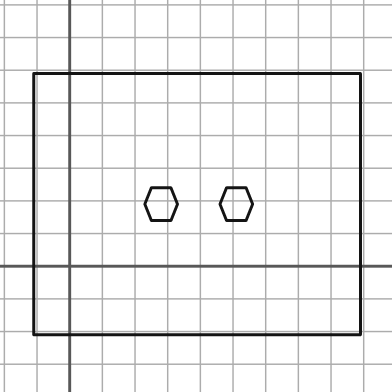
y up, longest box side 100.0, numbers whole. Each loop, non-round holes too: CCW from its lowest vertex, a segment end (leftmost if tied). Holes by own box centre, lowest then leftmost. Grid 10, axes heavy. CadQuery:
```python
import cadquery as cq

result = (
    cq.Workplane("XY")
    .moveTo(-11.0, -21.0)
    .lineTo(89.0, -21.0)
    .lineTo(89.0, 59.0)
    .lineTo(-11.0, 59.0)
    .close()
    .moveTo(25.0, 14.0)
    .lineTo(31.0, 14.0)
    .lineTo(33.0, 19.0)
    .lineTo(31.0, 24.0)
    .lineTo(25.0, 24.0)
    .lineTo(23.0, 19.0)
    .close()
    .moveTo(48.0, 14.0)
    .lineTo(54.0, 14.0)
    .lineTo(56.0, 19.0)
    .lineTo(54.0, 24.0)
    .lineTo(48.0, 24.0)
    .lineTo(46.0, 19.0)
    .close()
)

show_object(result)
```